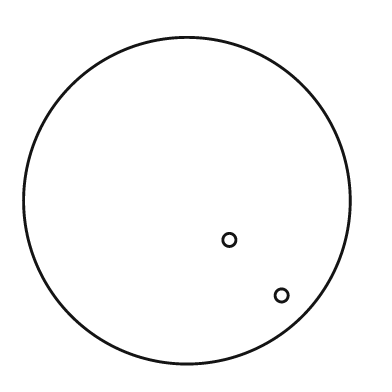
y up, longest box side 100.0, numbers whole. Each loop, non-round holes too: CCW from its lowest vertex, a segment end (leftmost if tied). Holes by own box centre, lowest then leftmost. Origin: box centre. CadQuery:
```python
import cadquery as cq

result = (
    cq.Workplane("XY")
    .moveTo(0.0, 0.0)
    .circle(50.0)
    .moveTo(29.0, -29.0)
    .circle(2.0)
    .moveTo(13.0, -12.0)
    .circle(2.0)
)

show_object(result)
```